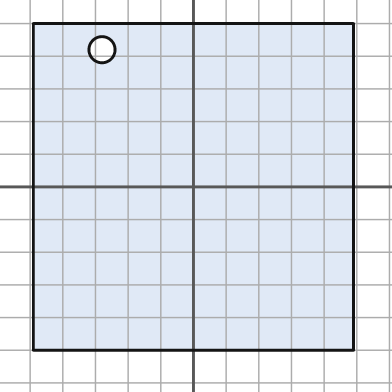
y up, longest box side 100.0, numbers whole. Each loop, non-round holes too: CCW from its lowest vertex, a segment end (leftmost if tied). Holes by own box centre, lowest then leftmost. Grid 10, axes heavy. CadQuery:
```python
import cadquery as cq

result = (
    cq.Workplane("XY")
    .moveTo(-49.0, -50.0)
    .lineTo(49.0, -50.0)
    .lineTo(49.0, 50.0)
    .lineTo(-49.0, 50.0)
    .close()
    .moveTo(-28.0, 42.0)
    .circle(4.0)
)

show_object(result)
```